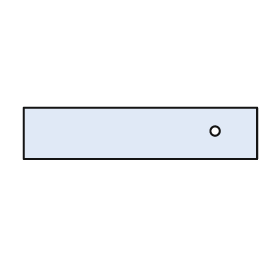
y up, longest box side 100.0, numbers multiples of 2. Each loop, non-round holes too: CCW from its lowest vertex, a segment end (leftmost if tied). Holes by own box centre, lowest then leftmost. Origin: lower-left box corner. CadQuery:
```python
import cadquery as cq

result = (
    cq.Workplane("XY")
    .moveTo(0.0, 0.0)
    .lineTo(100.0, 0.0)
    .lineTo(100.0, 22.0)
    .lineTo(0.0, 22.0)
    .close()
    .moveTo(82.0, 12.0)
    .circle(2.0)
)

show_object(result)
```